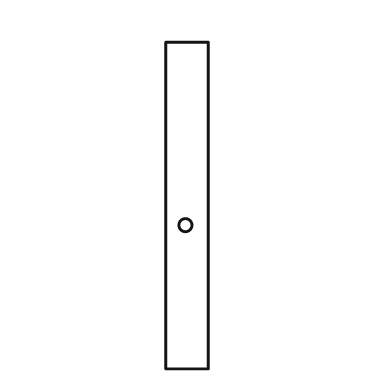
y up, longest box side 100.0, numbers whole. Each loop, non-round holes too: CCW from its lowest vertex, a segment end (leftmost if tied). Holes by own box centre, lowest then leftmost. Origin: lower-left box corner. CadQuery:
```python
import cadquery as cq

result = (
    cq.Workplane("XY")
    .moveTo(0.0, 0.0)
    .lineTo(13.0, 0.0)
    .lineTo(13.0, 100.0)
    .lineTo(0.0, 100.0)
    .close()
    .moveTo(6.0, 44.0)
    .circle(2.0)
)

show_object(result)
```